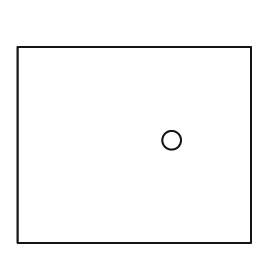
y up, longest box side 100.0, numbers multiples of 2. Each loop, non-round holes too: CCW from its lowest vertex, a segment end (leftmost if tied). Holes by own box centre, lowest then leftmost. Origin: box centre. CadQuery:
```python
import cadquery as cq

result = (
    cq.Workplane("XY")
    .moveTo(-50.0, -42.0)
    .lineTo(50.0, -42.0)
    .lineTo(50.0, 42.0)
    .lineTo(-50.0, 42.0)
    .close()
    .moveTo(16.0, 2.0)
    .circle(4.0)
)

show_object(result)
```